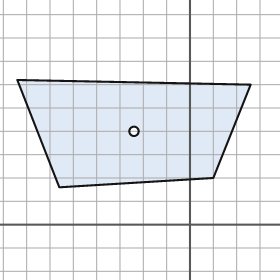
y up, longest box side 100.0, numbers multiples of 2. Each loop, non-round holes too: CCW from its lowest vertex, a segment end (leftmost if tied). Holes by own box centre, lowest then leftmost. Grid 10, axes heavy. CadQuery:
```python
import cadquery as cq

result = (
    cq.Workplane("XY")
    .moveTo(-56.0, 16.0)
    .lineTo(10.0, 20.0)
    .lineTo(26.0, 60.0)
    .lineTo(-74.0, 62.0)
    .close()
    .moveTo(-24.0, 40.0)
    .circle(2.0)
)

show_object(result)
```